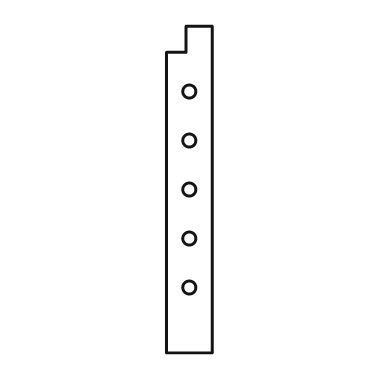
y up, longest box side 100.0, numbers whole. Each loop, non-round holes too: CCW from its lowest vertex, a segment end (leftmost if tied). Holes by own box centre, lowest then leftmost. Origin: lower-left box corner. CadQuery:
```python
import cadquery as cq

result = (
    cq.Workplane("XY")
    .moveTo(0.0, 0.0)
    .lineTo(14.0, 0.0)
    .lineTo(14.0, 100.0)
    .lineTo(6.0, 100.0)
    .lineTo(6.0, 92.0)
    .lineTo(0.0, 92.0)
    .close()
    .moveTo(7.0, 20.0)
    .circle(2.0)
    .moveTo(7.0, 35.0)
    .circle(2.0)
    .moveTo(7.0, 50.0)
    .circle(2.0)
    .moveTo(7.0, 65.0)
    .circle(2.0)
    .moveTo(7.0, 80.0)
    .circle(2.0)
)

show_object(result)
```